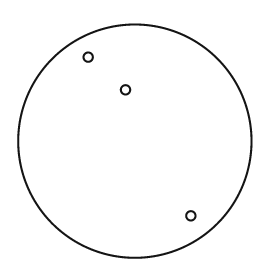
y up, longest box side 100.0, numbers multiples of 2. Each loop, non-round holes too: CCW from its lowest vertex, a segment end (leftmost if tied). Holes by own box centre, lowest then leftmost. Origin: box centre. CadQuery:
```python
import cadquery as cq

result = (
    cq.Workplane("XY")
    .moveTo(0.0, 0.0)
    .circle(50.0)
    .moveTo(24.0, -32.0)
    .circle(2.0)
    .moveTo(-4.0, 22.0)
    .circle(2.0)
    .moveTo(-20.0, 36.0)
    .circle(2.0)
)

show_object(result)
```